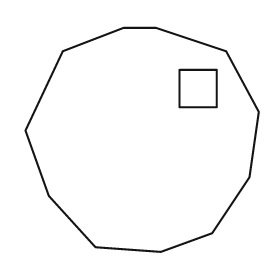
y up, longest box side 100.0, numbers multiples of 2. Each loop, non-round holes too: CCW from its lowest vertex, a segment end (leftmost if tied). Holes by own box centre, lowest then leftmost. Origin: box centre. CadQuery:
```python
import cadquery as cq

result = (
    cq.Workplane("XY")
    .moveTo(8.0, -48.0)
    .lineTo(30.0, -40.0)
    .lineTo(46.0, -16.0)
    .lineTo(50.0, 12.0)
    .lineTo(36.0, 38.0)
    .lineTo(6.0, 48.0)
    .lineTo(-8.0, 48.0)
    .lineTo(-34.0, 38.0)
    .lineTo(-50.0, 4.0)
    .lineTo(-40.0, -24.0)
    .lineTo(-20.0, -46.0)
    .close()
    .moveTo(16.0, 14.0)
    .lineTo(32.0, 14.0)
    .lineTo(32.0, 30.0)
    .lineTo(16.0, 30.0)
    .close()
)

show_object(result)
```